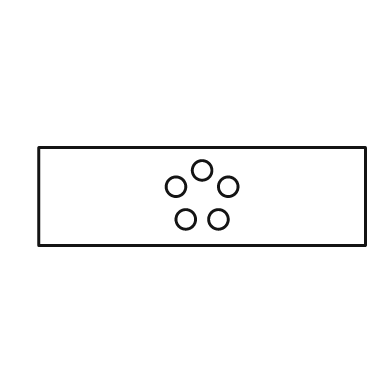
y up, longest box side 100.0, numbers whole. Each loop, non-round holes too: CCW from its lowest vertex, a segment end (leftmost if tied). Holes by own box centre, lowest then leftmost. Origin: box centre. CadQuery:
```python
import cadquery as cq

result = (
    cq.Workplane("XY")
    .moveTo(-50.0, -15.0)
    .lineTo(50.0, -15.0)
    .lineTo(50.0, 15.0)
    .lineTo(-50.0, 15.0)
    .close()
    .moveTo(-5.0, -7.0)
    .circle(3.0)
    .moveTo(5.0, -7.0)
    .circle(3.0)
    .moveTo(-8.0, 3.0)
    .circle(3.0)
    .moveTo(8.0, 3.0)
    .circle(3.0)
    .moveTo(0.0, 8.0)
    .circle(3.0)
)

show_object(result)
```